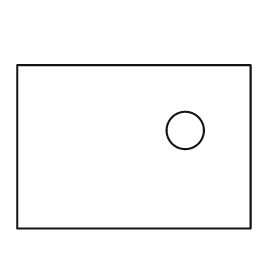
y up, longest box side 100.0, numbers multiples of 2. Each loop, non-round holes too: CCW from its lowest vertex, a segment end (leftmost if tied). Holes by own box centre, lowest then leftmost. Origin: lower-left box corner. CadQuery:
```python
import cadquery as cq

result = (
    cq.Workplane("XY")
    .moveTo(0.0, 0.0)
    .lineTo(100.0, 0.0)
    .lineTo(100.0, 70.0)
    .lineTo(0.0, 70.0)
    .close()
    .moveTo(72.0, 42.0)
    .circle(8.0)
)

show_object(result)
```